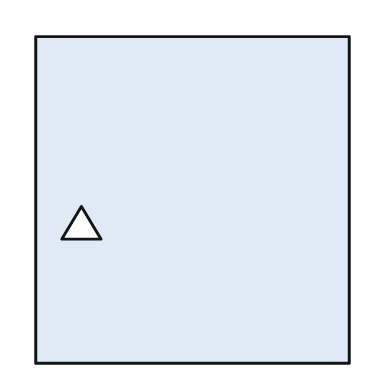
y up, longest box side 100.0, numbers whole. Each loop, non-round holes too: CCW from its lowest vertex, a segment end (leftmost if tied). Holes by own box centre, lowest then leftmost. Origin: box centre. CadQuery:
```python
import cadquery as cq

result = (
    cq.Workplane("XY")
    .moveTo(-48.0, -50.0)
    .lineTo(48.0, -50.0)
    .lineTo(48.0, 50.0)
    .lineTo(-48.0, 50.0)
    .close()
    .moveTo(-40.0, -12.0)
    .lineTo(-28.0, -12.0)
    .lineTo(-34.0, -2.0)
    .close()
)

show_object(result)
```